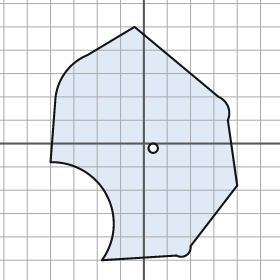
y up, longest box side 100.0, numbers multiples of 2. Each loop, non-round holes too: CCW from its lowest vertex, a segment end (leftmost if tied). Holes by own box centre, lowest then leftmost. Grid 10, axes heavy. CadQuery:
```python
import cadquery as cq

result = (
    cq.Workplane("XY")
    .moveTo(-18.0, -50.0)
    .lineTo(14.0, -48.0)
    .threePointArc((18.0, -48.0), (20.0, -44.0))
    .lineTo(40.0, -18.0)
    .lineTo(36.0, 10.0)
    .threePointArc((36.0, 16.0), (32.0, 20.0))
    .lineTo(-4.0, 50.0)
    .lineTo(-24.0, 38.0)
    .threePointArc((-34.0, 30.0), (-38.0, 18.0))
    .lineTo(-40.0, -8.0)
    .threePointArc((-16.0, -22.0), (-18.0, -50.0))
    .close()
    .moveTo(4.0, -2.0)
    .circle(2.0)
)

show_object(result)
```